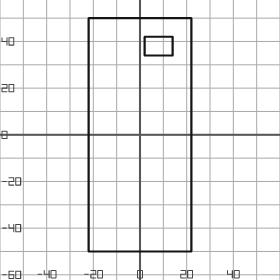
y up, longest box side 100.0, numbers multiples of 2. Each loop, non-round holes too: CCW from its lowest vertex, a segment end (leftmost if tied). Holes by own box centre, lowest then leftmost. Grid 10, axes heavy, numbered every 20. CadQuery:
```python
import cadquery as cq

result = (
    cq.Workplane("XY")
    .moveTo(-22.0, -50.0)
    .lineTo(22.0, -50.0)
    .lineTo(22.0, 50.0)
    .lineTo(-22.0, 50.0)
    .close()
    .moveTo(2.0, 34.0)
    .lineTo(14.0, 34.0)
    .lineTo(14.0, 42.0)
    .lineTo(2.0, 42.0)
    .close()
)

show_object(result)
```